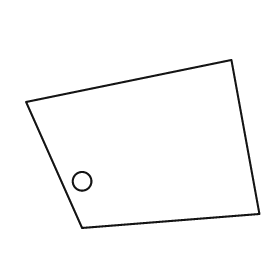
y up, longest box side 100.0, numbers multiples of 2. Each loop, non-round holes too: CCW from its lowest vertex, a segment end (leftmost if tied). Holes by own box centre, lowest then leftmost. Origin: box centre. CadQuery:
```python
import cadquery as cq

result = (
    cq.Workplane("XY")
    .moveTo(-26.0, -36.0)
    .lineTo(50.0, -30.0)
    .lineTo(38.0, 36.0)
    .lineTo(-50.0, 18.0)
    .close()
    .moveTo(-26.0, -16.0)
    .circle(4.0)
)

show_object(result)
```